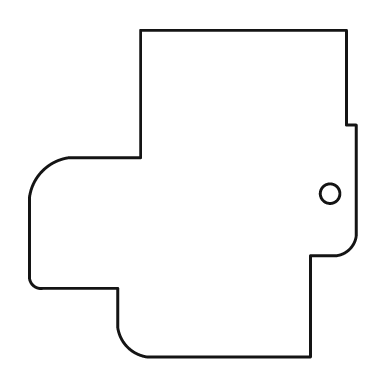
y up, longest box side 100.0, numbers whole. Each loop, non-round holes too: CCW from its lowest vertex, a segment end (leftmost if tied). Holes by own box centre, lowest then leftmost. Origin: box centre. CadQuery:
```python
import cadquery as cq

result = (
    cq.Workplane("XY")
    .moveTo(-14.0, -50.0)
    .lineTo(36.0, -50.0)
    .lineTo(36.0, -19.0)
    .lineTo(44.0, -19.0)
    .threePointArc((48.0, -17.0), (50.0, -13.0))
    .lineTo(50.0, 21.0)
    .lineTo(47.0, 21.0)
    .lineTo(47.0, 50.0)
    .lineTo(-16.0, 50.0)
    .lineTo(-16.0, 11.0)
    .lineTo(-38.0, 11.0)
    .threePointArc((-46.0, 7.0), (-50.0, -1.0))
    .lineTo(-50.0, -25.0)
    .threePointArc((-49.0, -28.0), (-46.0, -29.0))
    .lineTo(-23.0, -29.0)
    .lineTo(-23.0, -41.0)
    .threePointArc((-20.0, -47.0), (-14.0, -50.0))
    .close()
    .moveTo(42.0, 0.0)
    .circle(3.0)
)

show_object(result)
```